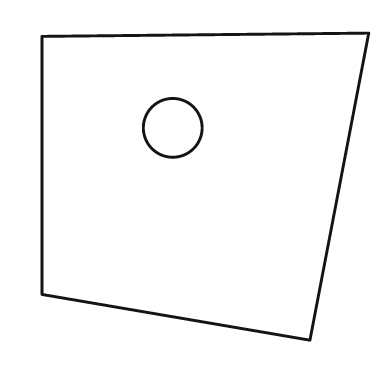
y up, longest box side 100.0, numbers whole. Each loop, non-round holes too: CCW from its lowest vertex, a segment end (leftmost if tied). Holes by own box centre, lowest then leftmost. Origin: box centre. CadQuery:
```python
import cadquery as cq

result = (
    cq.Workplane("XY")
    .moveTo(32.0, -47.0)
    .lineTo(50.0, 47.0)
    .lineTo(-50.0, 46.0)
    .lineTo(-50.0, -33.0)
    .close()
    .moveTo(-10.0, 18.0)
    .circle(9.0)
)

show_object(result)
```